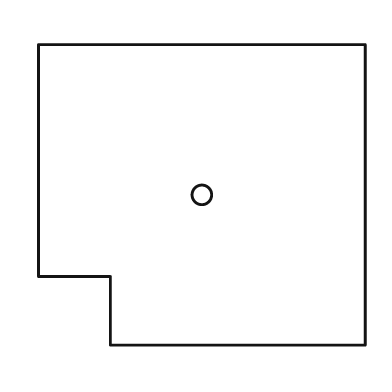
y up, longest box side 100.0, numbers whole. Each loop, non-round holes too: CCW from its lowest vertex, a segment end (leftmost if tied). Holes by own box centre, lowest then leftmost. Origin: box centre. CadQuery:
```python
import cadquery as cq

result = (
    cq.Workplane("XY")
    .moveTo(-28.0, -46.0)
    .lineTo(50.0, -46.0)
    .lineTo(50.0, 46.0)
    .lineTo(-50.0, 46.0)
    .lineTo(-50.0, -25.0)
    .lineTo(-28.0, -25.0)
    .close()
    .moveTo(0.0, 0.0)
    .circle(3.0)
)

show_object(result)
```